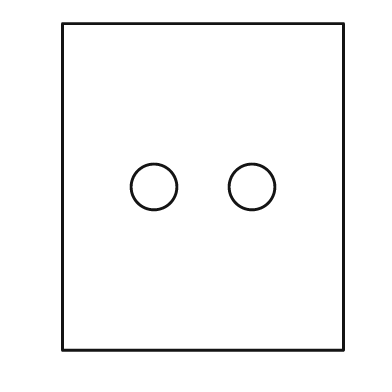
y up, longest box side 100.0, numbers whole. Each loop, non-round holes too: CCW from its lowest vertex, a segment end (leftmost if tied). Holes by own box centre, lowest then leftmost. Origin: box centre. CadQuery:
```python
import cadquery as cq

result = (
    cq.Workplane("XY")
    .moveTo(-43.0, -50.0)
    .lineTo(43.0, -50.0)
    .lineTo(43.0, 50.0)
    .lineTo(-43.0, 50.0)
    .close()
    .moveTo(-15.0, 0.0)
    .circle(7.0)
    .moveTo(15.0, 0.0)
    .circle(7.0)
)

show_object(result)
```